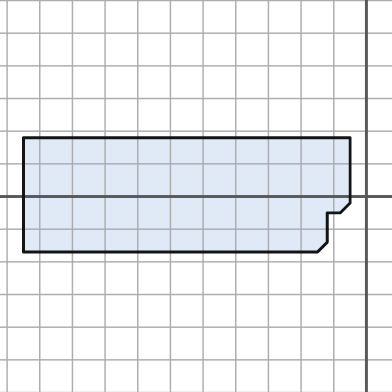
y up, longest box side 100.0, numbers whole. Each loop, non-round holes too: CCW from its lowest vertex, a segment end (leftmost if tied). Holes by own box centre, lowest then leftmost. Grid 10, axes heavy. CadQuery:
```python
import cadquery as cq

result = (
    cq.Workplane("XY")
    .moveTo(-105.0, -17.0)
    .lineTo(-15.0, -17.0)
    .lineTo(-12.0, -14.0)
    .lineTo(-12.0, -5.0)
    .lineTo(-8.0, -5.0)
    .lineTo(-5.0, -2.0)
    .lineTo(-5.0, 18.0)
    .lineTo(-105.0, 18.0)
    .close()
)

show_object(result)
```